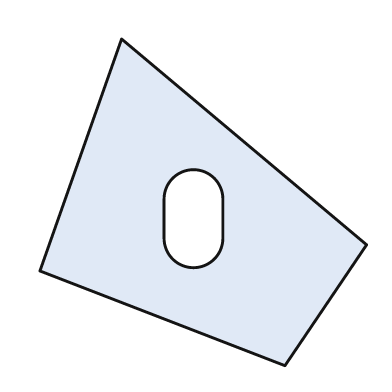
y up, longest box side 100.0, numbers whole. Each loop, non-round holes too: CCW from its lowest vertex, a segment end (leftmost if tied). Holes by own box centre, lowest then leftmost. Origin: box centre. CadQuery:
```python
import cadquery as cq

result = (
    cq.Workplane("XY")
    .moveTo(25.0, -50.0)
    .lineTo(50.0, -13.0)
    .lineTo(-25.0, 50.0)
    .lineTo(-50.0, -21.0)
    .close()
    .moveTo(-12.0, -11.0)
    .threePointArc((-3.0, -20.0), (6.0, -11.0))
    .lineTo(6.0, 1.0)
    .threePointArc((-3.0, 10.0), (-12.0, 1.0))
    .close()
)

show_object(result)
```